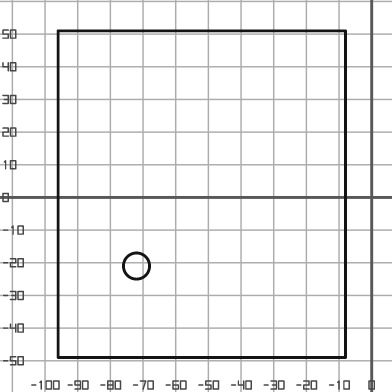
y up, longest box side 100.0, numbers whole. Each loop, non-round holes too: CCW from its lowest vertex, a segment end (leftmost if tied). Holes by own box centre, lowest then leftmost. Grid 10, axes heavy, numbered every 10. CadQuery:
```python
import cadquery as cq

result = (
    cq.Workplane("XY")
    .moveTo(-96.0, -49.0)
    .lineTo(-8.0, -49.0)
    .lineTo(-8.0, 51.0)
    .lineTo(-96.0, 51.0)
    .close()
    .moveTo(-72.0, -21.0)
    .circle(4.0)
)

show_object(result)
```